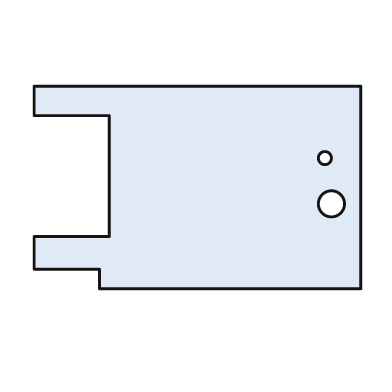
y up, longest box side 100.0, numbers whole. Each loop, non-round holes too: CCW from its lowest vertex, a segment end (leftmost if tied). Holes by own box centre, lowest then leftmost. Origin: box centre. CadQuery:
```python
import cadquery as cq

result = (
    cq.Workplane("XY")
    .moveTo(-30.0, -31.0)
    .lineTo(50.0, -31.0)
    .lineTo(50.0, 31.0)
    .lineTo(-50.0, 31.0)
    .lineTo(-50.0, 22.0)
    .lineTo(-27.0, 22.0)
    .lineTo(-27.0, -15.0)
    .lineTo(-50.0, -15.0)
    .lineTo(-50.0, -25.0)
    .lineTo(-30.0, -25.0)
    .close()
    .moveTo(41.0, -5.0)
    .circle(4.0)
    .moveTo(39.0, 9.0)
    .circle(2.0)
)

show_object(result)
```